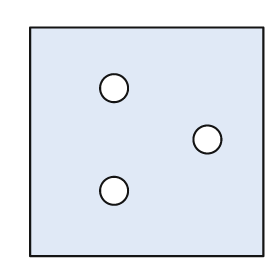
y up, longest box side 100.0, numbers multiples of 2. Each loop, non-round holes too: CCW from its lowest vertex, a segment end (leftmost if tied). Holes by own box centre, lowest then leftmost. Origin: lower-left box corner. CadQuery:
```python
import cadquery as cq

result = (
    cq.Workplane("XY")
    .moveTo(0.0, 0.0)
    .lineTo(100.0, 0.0)
    .lineTo(100.0, 98.0)
    .lineTo(0.0, 98.0)
    .close()
    .moveTo(36.0, 28.0)
    .circle(6.0)
    .moveTo(76.0, 50.0)
    .circle(6.0)
    .moveTo(36.0, 72.0)
    .circle(6.0)
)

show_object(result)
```